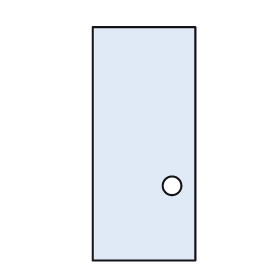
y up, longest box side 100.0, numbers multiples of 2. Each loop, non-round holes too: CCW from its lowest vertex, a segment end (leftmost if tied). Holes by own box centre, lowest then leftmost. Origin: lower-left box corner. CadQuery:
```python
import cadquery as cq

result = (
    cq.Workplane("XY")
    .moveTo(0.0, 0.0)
    .lineTo(44.0, 0.0)
    .lineTo(44.0, 100.0)
    .lineTo(0.0, 100.0)
    .close()
    .moveTo(34.0, 32.0)
    .circle(4.0)
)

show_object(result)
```